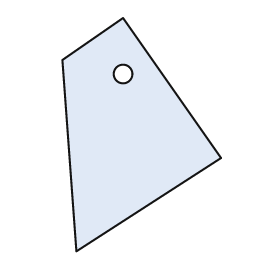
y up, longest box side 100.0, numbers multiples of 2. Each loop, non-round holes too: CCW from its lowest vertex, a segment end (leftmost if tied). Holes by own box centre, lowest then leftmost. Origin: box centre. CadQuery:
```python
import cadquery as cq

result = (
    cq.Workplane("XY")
    .moveTo(-28.0, -50.0)
    .lineTo(34.0, -10.0)
    .lineTo(-8.0, 50.0)
    .lineTo(-34.0, 32.0)
    .close()
    .moveTo(-8.0, 26.0)
    .circle(4.0)
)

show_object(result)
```